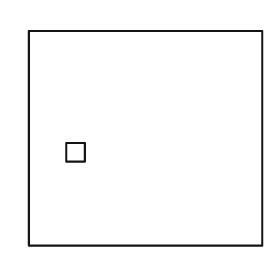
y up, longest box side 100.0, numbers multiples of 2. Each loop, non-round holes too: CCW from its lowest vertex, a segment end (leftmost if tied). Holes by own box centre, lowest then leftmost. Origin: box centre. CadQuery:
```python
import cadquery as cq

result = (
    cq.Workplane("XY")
    .moveTo(-50.0, -46.0)
    .lineTo(50.0, -46.0)
    .lineTo(50.0, 46.0)
    .lineTo(-50.0, 46.0)
    .close()
    .moveTo(-34.0, -10.0)
    .lineTo(-26.0, -10.0)
    .lineTo(-26.0, -2.0)
    .lineTo(-34.0, -2.0)
    .close()
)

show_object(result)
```